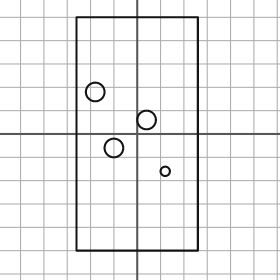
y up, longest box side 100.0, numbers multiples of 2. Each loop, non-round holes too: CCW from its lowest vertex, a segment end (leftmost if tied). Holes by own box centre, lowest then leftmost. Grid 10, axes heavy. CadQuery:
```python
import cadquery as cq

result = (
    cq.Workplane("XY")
    .moveTo(-26.0, -50.0)
    .lineTo(26.0, -50.0)
    .lineTo(26.0, 50.0)
    .lineTo(-26.0, 50.0)
    .close()
    .moveTo(12.0, -16.0)
    .circle(2.0)
    .moveTo(-10.0, -6.0)
    .circle(4.0)
    .moveTo(4.0, 6.0)
    .circle(4.0)
    .moveTo(-18.0, 18.0)
    .circle(4.0)
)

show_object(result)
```